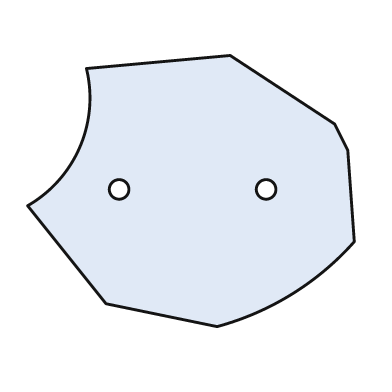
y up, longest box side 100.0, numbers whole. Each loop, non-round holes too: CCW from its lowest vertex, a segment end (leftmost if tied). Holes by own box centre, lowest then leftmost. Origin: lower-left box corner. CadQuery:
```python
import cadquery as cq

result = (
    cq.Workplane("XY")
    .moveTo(58.0, 0.0)
    .threePointArc((81.0, 10.0), (100.0, 26.0))
    .lineTo(98.0, 54.0)
    .lineTo(94.0, 62.0)
    .lineTo(62.0, 83.0)
    .lineTo(18.0, 79.0)
    .threePointArc((16.0, 55.0), (0.0, 37.0))
    .lineTo(24.0, 7.0)
    .close()
    .moveTo(28.0, 42.0)
    .circle(3.0)
    .moveTo(73.0, 42.0)
    .circle(3.0)
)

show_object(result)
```